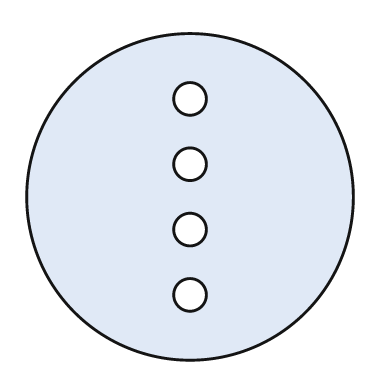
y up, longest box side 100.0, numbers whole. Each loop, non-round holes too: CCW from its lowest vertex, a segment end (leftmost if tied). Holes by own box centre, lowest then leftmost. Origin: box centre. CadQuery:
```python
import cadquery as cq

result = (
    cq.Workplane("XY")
    .moveTo(0.0, 0.0)
    .circle(50.0)
    .moveTo(0.0, -30.0)
    .circle(5.0)
    .moveTo(0.0, -10.0)
    .circle(5.0)
    .moveTo(0.0, 10.0)
    .circle(5.0)
    .moveTo(0.0, 30.0)
    .circle(5.0)
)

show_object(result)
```